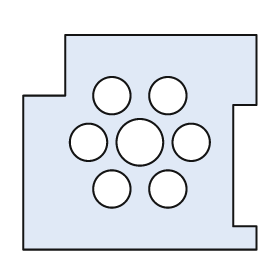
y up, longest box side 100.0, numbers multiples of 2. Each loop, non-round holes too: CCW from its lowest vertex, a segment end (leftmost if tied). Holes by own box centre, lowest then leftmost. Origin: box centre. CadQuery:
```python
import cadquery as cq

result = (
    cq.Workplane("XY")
    .moveTo(-50.0, -46.0)
    .lineTo(50.0, -46.0)
    .lineTo(50.0, -36.0)
    .lineTo(40.0, -36.0)
    .lineTo(40.0, 16.0)
    .lineTo(50.0, 16.0)
    .lineTo(50.0, 46.0)
    .lineTo(-32.0, 46.0)
    .lineTo(-32.0, 20.0)
    .lineTo(-50.0, 20.0)
    .close()
    .moveTo(-12.0, -20.0)
    .circle(8.0)
    .moveTo(12.0, -20.0)
    .circle(8.0)
    .moveTo(-22.0, 0.0)
    .circle(8.0)
    .moveTo(0.0, 0.0)
    .circle(10.0)
    .moveTo(22.0, 0.0)
    .circle(8.0)
    .moveTo(-12.0, 20.0)
    .circle(8.0)
    .moveTo(12.0, 20.0)
    .circle(8.0)
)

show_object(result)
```